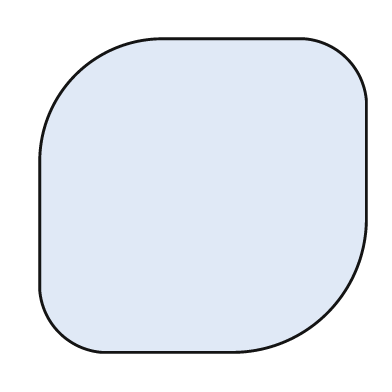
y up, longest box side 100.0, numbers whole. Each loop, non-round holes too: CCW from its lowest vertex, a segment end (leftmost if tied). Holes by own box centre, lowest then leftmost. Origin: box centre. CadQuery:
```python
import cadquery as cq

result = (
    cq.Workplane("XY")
    .moveTo(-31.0, -48.0)
    .lineTo(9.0, -48.0)
    .threePointArc((38.0, -36.0), (50.0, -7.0))
    .lineTo(50.0, 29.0)
    .threePointArc((44.0, 42.0), (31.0, 48.0))
    .lineTo(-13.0, 48.0)
    .threePointArc((-39.0, 37.0), (-50.0, 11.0))
    .lineTo(-50.0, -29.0)
    .threePointArc((-44.0, -42.0), (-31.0, -48.0))
    .close()
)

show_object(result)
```